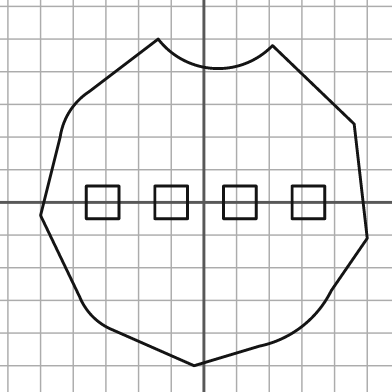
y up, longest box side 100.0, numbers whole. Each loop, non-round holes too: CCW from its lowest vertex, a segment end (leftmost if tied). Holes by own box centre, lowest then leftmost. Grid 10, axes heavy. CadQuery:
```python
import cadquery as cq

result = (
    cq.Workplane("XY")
    .moveTo(-3.0, -50.0)
    .lineTo(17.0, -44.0)
    .threePointArc((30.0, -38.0), (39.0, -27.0))
    .lineTo(50.0, -11.0)
    .lineTo(46.0, 24.0)
    .lineTo(21.0, 48.0)
    .threePointArc((3.0, 41.0), (-14.0, 50.0))
    .lineTo(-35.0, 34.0)
    .threePointArc((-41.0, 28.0), (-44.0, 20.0))
    .lineTo(-50.0, -4.0)
    .lineTo(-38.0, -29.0)
    .threePointArc((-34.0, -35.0), (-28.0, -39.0))
    .close()
    .moveTo(-36.0, -5.0)
    .lineTo(-26.0, -5.0)
    .lineTo(-26.0, 5.0)
    .lineTo(-36.0, 5.0)
    .close()
    .moveTo(-15.0, -5.0)
    .lineTo(-5.0, -5.0)
    .lineTo(-5.0, 5.0)
    .lineTo(-15.0, 5.0)
    .close()
    .moveTo(6.0, -5.0)
    .lineTo(16.0, -5.0)
    .lineTo(16.0, 5.0)
    .lineTo(6.0, 5.0)
    .close()
    .moveTo(27.0, -5.0)
    .lineTo(37.0, -5.0)
    .lineTo(37.0, 5.0)
    .lineTo(27.0, 5.0)
    .close()
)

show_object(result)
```